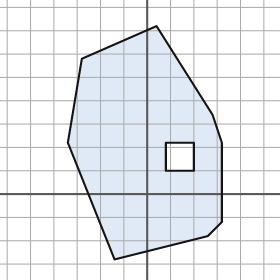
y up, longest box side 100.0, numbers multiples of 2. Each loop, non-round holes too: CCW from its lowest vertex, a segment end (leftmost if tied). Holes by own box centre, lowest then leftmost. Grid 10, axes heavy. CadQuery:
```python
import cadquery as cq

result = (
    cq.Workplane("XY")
    .moveTo(-14.0, -28.0)
    .lineTo(26.0, -18.0)
    .lineTo(32.0, -12.0)
    .lineTo(32.0, 22.0)
    .lineTo(28.0, 34.0)
    .lineTo(4.0, 72.0)
    .lineTo(-28.0, 58.0)
    .lineTo(-34.0, 22.0)
    .close()
    .moveTo(8.0, 10.0)
    .lineTo(20.0, 10.0)
    .lineTo(20.0, 22.0)
    .lineTo(8.0, 22.0)
    .close()
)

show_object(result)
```